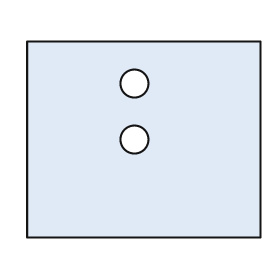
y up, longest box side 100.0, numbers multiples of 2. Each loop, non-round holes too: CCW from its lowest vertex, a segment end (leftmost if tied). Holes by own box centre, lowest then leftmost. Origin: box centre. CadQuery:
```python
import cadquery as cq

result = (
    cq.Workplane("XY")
    .moveTo(-50.0, -42.0)
    .lineTo(50.0, -42.0)
    .lineTo(50.0, 42.0)
    .lineTo(-50.0, 42.0)
    .close()
    .moveTo(-4.0, 0.0)
    .circle(6.0)
    .moveTo(-4.0, 24.0)
    .circle(6.0)
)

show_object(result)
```